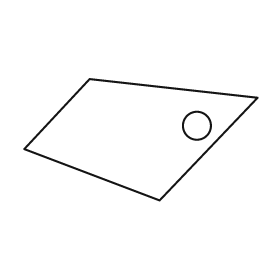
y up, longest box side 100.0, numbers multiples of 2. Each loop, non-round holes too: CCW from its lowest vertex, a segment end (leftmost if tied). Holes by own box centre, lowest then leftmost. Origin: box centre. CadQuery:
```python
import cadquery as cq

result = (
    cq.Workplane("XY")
    .moveTo(8.0, -26.0)
    .lineTo(50.0, 18.0)
    .lineTo(-22.0, 26.0)
    .lineTo(-50.0, -4.0)
    .close()
    .moveTo(24.0, 6.0)
    .circle(6.0)
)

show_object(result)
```